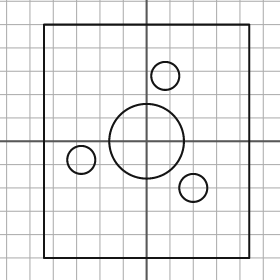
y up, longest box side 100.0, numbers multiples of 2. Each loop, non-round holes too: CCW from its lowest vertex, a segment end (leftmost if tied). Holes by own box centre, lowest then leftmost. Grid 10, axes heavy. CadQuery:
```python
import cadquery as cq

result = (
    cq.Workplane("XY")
    .moveTo(-44.0, -50.0)
    .lineTo(44.0, -50.0)
    .lineTo(44.0, 50.0)
    .lineTo(-44.0, 50.0)
    .close()
    .moveTo(20.0, -20.0)
    .circle(6.0)
    .moveTo(-28.0, -8.0)
    .circle(6.0)
    .moveTo(0.0, 0.0)
    .circle(16.0)
    .moveTo(8.0, 28.0)
    .circle(6.0)
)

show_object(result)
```